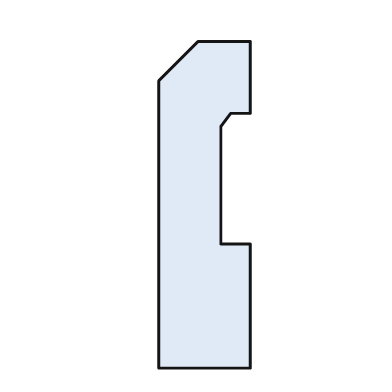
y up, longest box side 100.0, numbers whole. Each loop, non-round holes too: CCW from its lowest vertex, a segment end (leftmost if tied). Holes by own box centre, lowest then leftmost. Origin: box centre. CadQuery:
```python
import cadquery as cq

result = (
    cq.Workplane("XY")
    .moveTo(-14.0, -50.0)
    .lineTo(14.0, -50.0)
    .lineTo(14.0, -12.0)
    .lineTo(5.0, -12.0)
    .lineTo(5.0, 24.0)
    .lineTo(8.0, 28.0)
    .lineTo(14.0, 28.0)
    .lineTo(14.0, 50.0)
    .lineTo(-2.0, 50.0)
    .lineTo(-14.0, 38.0)
    .close()
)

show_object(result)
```